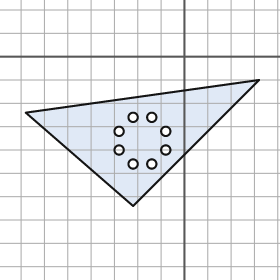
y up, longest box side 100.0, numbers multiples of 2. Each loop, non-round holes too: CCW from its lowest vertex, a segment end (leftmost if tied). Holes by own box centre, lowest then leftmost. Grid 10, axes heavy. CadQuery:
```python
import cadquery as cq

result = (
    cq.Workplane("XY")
    .moveTo(-22.0, -64.0)
    .lineTo(32.0, -10.0)
    .lineTo(-68.0, -24.0)
    .close()
    .moveTo(-22.0, -46.0)
    .circle(2.0)
    .moveTo(-14.0, -46.0)
    .circle(2.0)
    .moveTo(-28.0, -40.0)
    .circle(2.0)
    .moveTo(-8.0, -40.0)
    .circle(2.0)
    .moveTo(-28.0, -32.0)
    .circle(2.0)
    .moveTo(-8.0, -32.0)
    .circle(2.0)
    .moveTo(-22.0, -26.0)
    .circle(2.0)
    .moveTo(-14.0, -26.0)
    .circle(2.0)
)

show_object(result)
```